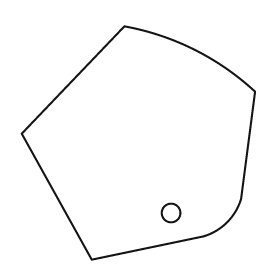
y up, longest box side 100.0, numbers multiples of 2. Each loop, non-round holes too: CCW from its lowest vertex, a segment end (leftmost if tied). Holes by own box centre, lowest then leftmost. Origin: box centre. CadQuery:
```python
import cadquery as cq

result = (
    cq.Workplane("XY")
    .moveTo(-20.0, -50.0)
    .lineTo(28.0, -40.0)
    .threePointArc((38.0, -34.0), (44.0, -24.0))
    .lineTo(50.0, 22.0)
    .threePointArc((24.0, 40.0), (-6.0, 50.0))
    .lineTo(-50.0, 4.0)
    .close()
    .moveTo(14.0, -30.0)
    .circle(4.0)
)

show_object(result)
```